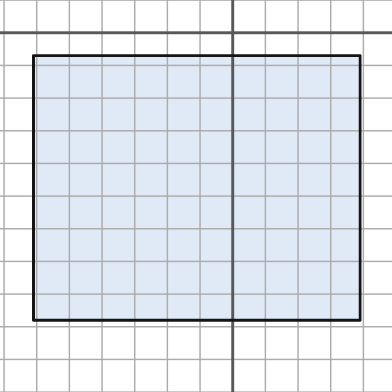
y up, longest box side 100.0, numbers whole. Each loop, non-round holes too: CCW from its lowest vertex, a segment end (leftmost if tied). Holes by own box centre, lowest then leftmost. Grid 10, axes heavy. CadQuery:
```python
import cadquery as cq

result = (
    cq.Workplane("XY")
    .moveTo(-61.0, -88.0)
    .lineTo(39.0, -88.0)
    .lineTo(39.0, -7.0)
    .lineTo(-61.0, -7.0)
    .close()
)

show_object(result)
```